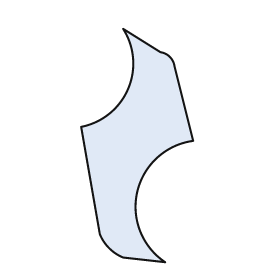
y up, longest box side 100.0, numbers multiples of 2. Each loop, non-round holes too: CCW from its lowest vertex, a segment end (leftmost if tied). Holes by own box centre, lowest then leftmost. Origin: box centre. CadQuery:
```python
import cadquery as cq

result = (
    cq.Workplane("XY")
    .moveTo(12.0, -50.0)
    .threePointArc((0.0, -20.0), (24.0, 2.0))
    .lineTo(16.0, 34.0)
    .threePointArc((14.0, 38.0), (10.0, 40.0))
    .lineTo(-6.0, 50.0)
    .threePointArc((-4.0, 24.0), (-24.0, 8.0))
    .lineTo(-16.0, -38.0)
    .threePointArc((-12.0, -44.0), (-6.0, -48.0))
    .close()
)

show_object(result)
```